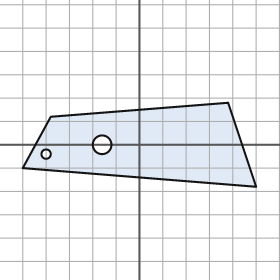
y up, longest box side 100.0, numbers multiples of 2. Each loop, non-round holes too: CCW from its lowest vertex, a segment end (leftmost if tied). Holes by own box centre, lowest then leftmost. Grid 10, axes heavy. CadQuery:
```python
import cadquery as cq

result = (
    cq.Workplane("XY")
    .moveTo(50.0, -18.0)
    .lineTo(38.0, 18.0)
    .lineTo(-38.0, 12.0)
    .lineTo(-50.0, -10.0)
    .close()
    .moveTo(-40.0, -4.0)
    .circle(2.0)
    .moveTo(-16.0, 0.0)
    .circle(4.0)
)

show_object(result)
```